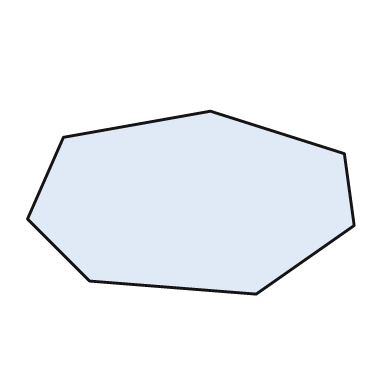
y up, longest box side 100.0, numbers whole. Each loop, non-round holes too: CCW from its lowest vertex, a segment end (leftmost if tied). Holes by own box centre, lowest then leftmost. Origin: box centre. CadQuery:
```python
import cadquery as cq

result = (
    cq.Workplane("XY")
    .moveTo(20.0, -28.0)
    .lineTo(50.0, -7.0)
    .lineTo(47.0, 15.0)
    .lineTo(6.0, 28.0)
    .lineTo(-39.0, 20.0)
    .lineTo(-50.0, -5.0)
    .lineTo(-31.0, -24.0)
    .close()
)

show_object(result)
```